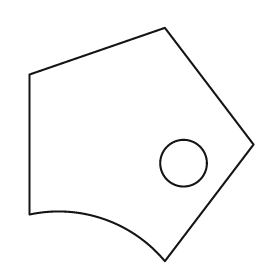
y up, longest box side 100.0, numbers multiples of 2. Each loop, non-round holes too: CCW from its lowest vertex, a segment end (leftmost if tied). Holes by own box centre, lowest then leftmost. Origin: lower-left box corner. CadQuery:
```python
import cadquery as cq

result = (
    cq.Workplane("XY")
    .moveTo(58.0, 0.0)
    .lineTo(96.0, 50.0)
    .lineTo(58.0, 100.0)
    .lineTo(0.0, 80.0)
    .lineTo(0.0, 20.0)
    .threePointArc((32.0, 18.0), (58.0, 0.0))
    .close()
    .moveTo(66.0, 42.0)
    .circle(10.0)
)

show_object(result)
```